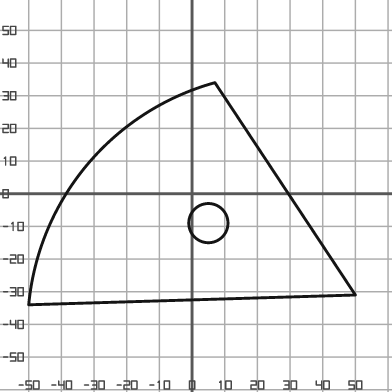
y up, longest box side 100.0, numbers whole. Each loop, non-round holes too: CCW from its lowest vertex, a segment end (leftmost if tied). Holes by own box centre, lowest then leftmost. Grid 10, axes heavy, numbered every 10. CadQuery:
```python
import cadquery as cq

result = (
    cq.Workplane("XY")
    .moveTo(-50.0, -34.0)
    .lineTo(50.0, -31.0)
    .lineTo(7.0, 34.0)
    .threePointArc((-32.0, 9.0), (-50.0, -34.0))
    .close()
    .moveTo(5.0, -9.0)
    .circle(6.0)
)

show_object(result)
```